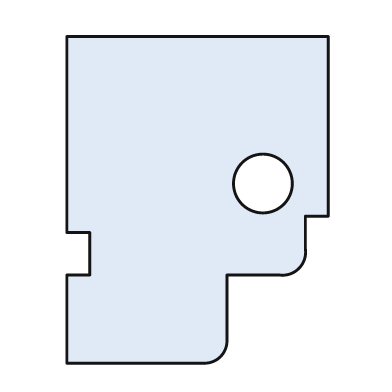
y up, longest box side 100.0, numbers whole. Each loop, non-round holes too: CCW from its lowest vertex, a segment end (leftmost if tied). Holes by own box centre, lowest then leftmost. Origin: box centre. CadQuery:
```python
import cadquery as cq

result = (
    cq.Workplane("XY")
    .moveTo(-40.0, -50.0)
    .lineTo(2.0, -50.0)
    .threePointArc((7.0, -48.0), (9.0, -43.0))
    .lineTo(9.0, -23.0)
    .lineTo(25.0, -23.0)
    .threePointArc((31.0, -21.0), (33.0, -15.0))
    .lineTo(33.0, -5.0)
    .lineTo(40.0, -5.0)
    .lineTo(40.0, 50.0)
    .lineTo(-40.0, 50.0)
    .lineTo(-40.0, -10.0)
    .lineTo(-33.0, -10.0)
    .lineTo(-33.0, -23.0)
    .lineTo(-40.0, -23.0)
    .close()
    .moveTo(20.0, 5.0)
    .circle(9.0)
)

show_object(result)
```